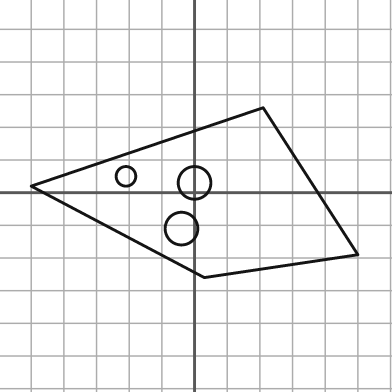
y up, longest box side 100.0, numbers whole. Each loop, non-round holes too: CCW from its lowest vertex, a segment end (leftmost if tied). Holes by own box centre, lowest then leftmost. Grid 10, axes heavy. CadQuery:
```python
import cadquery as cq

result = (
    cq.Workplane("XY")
    .moveTo(3.0, -26.0)
    .lineTo(50.0, -19.0)
    .lineTo(21.0, 26.0)
    .lineTo(-50.0, 2.0)
    .close()
    .moveTo(-4.0, -11.0)
    .circle(5.0)
    .moveTo(0.0, 3.0)
    .circle(5.0)
    .moveTo(-21.0, 5.0)
    .circle(3.0)
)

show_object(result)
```